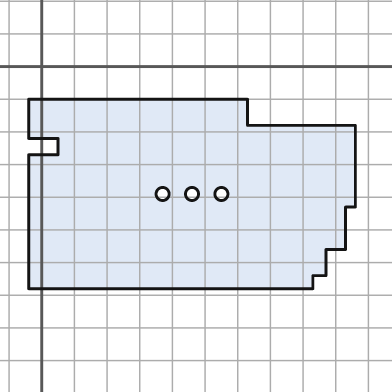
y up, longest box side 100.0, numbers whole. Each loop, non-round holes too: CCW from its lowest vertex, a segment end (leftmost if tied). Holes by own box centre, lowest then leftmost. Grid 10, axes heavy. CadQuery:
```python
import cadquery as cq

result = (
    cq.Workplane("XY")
    .moveTo(-4.0, -68.0)
    .lineTo(83.0, -68.0)
    .lineTo(83.0, -64.0)
    .lineTo(87.0, -64.0)
    .lineTo(87.0, -56.0)
    .lineTo(93.0, -56.0)
    .lineTo(93.0, -43.0)
    .lineTo(96.0, -43.0)
    .lineTo(96.0, -18.0)
    .lineTo(63.0, -18.0)
    .lineTo(63.0, -10.0)
    .lineTo(-4.0, -10.0)
    .lineTo(-4.0, -22.0)
    .lineTo(5.0, -22.0)
    .lineTo(5.0, -27.0)
    .lineTo(-4.0, -27.0)
    .close()
    .moveTo(37.0, -39.0)
    .circle(2.0)
    .moveTo(46.0, -39.0)
    .circle(2.0)
    .moveTo(55.0, -39.0)
    .circle(2.0)
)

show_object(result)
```